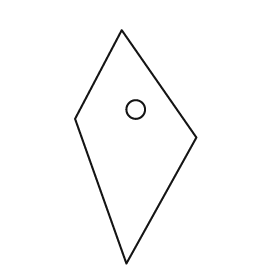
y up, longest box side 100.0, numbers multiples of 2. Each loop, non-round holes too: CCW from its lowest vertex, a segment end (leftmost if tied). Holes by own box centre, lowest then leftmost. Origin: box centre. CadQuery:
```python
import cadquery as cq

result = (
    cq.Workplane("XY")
    .moveTo(-4.0, -50.0)
    .lineTo(26.0, 4.0)
    .lineTo(-6.0, 50.0)
    .lineTo(-26.0, 12.0)
    .close()
    .moveTo(0.0, 16.0)
    .circle(4.0)
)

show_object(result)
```